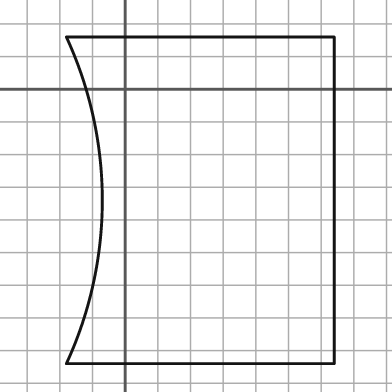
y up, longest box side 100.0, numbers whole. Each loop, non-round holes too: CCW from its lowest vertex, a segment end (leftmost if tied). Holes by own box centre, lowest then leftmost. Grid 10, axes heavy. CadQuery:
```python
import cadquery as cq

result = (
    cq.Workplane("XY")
    .moveTo(-18.0, -84.0)
    .lineTo(64.0, -84.0)
    .lineTo(64.0, 16.0)
    .lineTo(-18.0, 16.0)
    .threePointArc((-7.0, -34.0), (-18.0, -84.0))
    .close()
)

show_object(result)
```